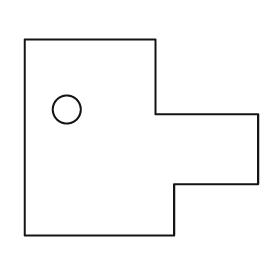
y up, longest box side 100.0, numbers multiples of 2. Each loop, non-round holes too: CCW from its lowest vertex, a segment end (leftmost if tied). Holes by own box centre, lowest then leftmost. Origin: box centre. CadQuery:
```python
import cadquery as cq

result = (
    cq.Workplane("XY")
    .moveTo(-50.0, -42.0)
    .lineTo(14.0, -42.0)
    .lineTo(14.0, -20.0)
    .lineTo(50.0, -20.0)
    .lineTo(50.0, 10.0)
    .lineTo(6.0, 10.0)
    .lineTo(6.0, 42.0)
    .lineTo(-50.0, 42.0)
    .close()
    .moveTo(-32.0, 12.0)
    .circle(6.0)
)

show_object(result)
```